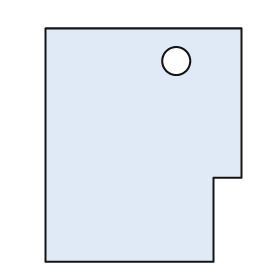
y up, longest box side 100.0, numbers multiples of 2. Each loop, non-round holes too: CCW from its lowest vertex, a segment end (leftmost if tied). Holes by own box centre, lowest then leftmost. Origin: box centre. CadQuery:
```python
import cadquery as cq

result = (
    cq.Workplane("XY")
    .moveTo(-42.0, -50.0)
    .lineTo(30.0, -50.0)
    .lineTo(30.0, -14.0)
    .lineTo(42.0, -14.0)
    .lineTo(42.0, 50.0)
    .lineTo(-42.0, 50.0)
    .close()
    .moveTo(14.0, 36.0)
    .circle(6.0)
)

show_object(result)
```